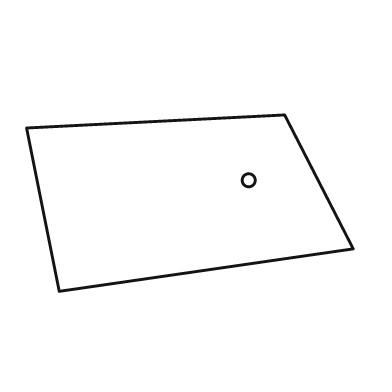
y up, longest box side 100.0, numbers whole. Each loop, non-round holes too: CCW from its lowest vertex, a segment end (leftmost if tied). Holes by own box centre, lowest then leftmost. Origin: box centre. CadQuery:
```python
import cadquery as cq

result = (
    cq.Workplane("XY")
    .moveTo(-40.0, -27.0)
    .lineTo(50.0, -14.0)
    .lineTo(29.0, 27.0)
    .lineTo(-50.0, 23.0)
    .close()
    .moveTo(18.0, 7.0)
    .circle(2.0)
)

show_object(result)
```